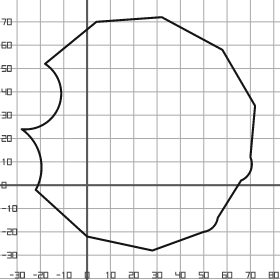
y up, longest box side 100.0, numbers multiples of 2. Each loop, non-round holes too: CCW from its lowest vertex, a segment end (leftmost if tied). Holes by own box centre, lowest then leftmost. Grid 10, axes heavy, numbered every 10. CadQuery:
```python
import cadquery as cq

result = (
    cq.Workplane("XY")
    .moveTo(28.0, -28.0)
    .lineTo(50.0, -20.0)
    .threePointArc((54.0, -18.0), (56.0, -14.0))
    .lineTo(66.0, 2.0)
    .threePointArc((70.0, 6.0), (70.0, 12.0))
    .lineTo(72.0, 34.0)
    .lineTo(58.0, 58.0)
    .lineTo(32.0, 72.0)
    .lineTo(4.0, 70.0)
    .lineTo(-18.0, 52.0)
    .threePointArc((-12.0, 34.0), (-28.0, 24.0))
    .threePointArc((-20.0, 12.0), (-22.0, -2.0))
    .lineTo(0.0, -22.0)
    .close()
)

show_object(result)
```